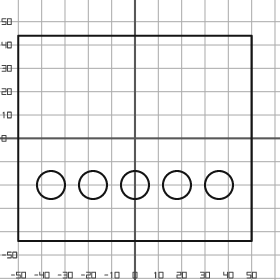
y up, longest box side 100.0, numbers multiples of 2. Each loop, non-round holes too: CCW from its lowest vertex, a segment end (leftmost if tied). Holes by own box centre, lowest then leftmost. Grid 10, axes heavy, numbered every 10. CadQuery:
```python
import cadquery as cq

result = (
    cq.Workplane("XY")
    .moveTo(-50.0, -44.0)
    .lineTo(50.0, -44.0)
    .lineTo(50.0, 44.0)
    .lineTo(-50.0, 44.0)
    .close()
    .moveTo(-36.0, -20.0)
    .circle(6.0)
    .moveTo(-18.0, -20.0)
    .circle(6.0)
    .moveTo(0.0, -20.0)
    .circle(6.0)
    .moveTo(18.0, -20.0)
    .circle(6.0)
    .moveTo(36.0, -20.0)
    .circle(6.0)
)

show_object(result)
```